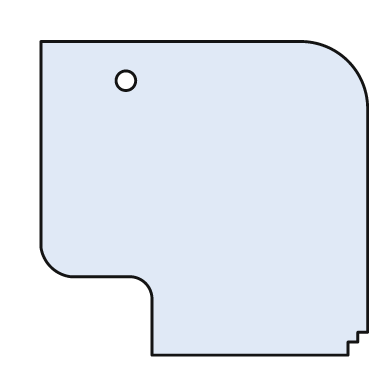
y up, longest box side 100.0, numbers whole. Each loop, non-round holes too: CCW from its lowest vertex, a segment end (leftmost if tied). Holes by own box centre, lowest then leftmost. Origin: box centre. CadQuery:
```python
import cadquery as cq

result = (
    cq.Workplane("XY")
    .moveTo(-16.0, -48.0)
    .lineTo(44.0, -48.0)
    .lineTo(44.0, -44.0)
    .lineTo(47.0, -44.0)
    .lineTo(47.0, -41.0)
    .lineTo(50.0, -41.0)
    .lineTo(50.0, 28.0)
    .threePointArc((44.0, 42.0), (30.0, 48.0))
    .lineTo(-50.0, 48.0)
    .lineTo(-50.0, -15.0)
    .threePointArc((-47.0, -21.0), (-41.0, -24.0))
    .lineTo(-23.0, -24.0)
    .threePointArc((-18.0, -26.0), (-16.0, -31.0))
    .close()
    .moveTo(-24.0, 36.0)
    .circle(3.0)
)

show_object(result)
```